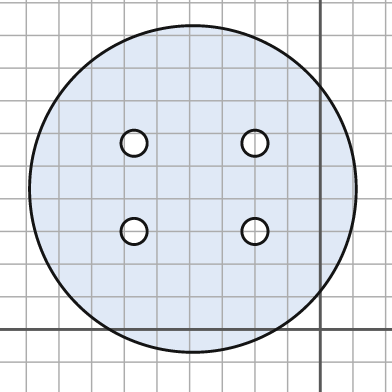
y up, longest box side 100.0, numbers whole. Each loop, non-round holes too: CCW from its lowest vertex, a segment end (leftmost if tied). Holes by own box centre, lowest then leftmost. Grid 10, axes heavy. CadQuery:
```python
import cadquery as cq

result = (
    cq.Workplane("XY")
    .moveTo(-39.0, 43.0)
    .circle(50.0)
    .moveTo(-57.0, 30.0)
    .circle(4.0)
    .moveTo(-20.0, 30.0)
    .circle(4.0)
    .moveTo(-57.0, 57.0)
    .circle(4.0)
    .moveTo(-20.0, 57.0)
    .circle(4.0)
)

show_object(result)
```